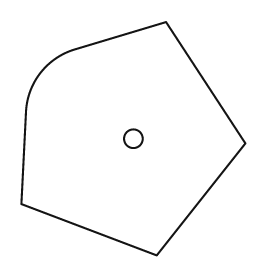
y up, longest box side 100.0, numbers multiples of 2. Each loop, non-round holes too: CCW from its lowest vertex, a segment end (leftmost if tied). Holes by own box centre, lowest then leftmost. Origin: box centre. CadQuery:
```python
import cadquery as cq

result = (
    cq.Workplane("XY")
    .moveTo(10.0, -50.0)
    .lineTo(48.0, -2.0)
    .lineTo(14.0, 50.0)
    .lineTo(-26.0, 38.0)
    .threePointArc((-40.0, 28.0), (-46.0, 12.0))
    .lineTo(-48.0, -28.0)
    .close()
    .moveTo(0.0, 0.0)
    .circle(4.0)
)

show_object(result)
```